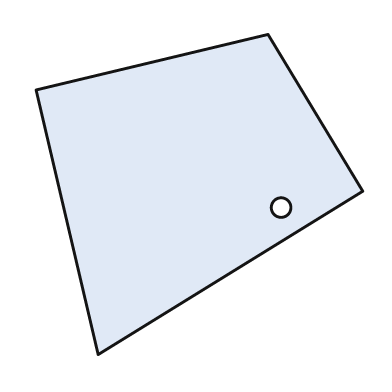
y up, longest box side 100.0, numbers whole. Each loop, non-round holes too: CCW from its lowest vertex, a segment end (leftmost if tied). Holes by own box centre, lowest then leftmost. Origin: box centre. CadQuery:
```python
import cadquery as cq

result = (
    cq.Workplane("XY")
    .moveTo(-31.0, -49.0)
    .lineTo(50.0, 1.0)
    .lineTo(21.0, 49.0)
    .lineTo(-50.0, 32.0)
    .close()
    .moveTo(25.0, -4.0)
    .circle(3.0)
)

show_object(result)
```